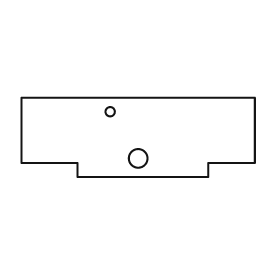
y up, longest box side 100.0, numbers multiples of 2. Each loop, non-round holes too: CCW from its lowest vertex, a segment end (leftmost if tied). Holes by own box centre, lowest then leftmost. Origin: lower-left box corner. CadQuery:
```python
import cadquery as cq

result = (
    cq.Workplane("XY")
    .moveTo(24.0, 0.0)
    .lineTo(80.0, 0.0)
    .lineTo(80.0, 6.0)
    .lineTo(100.0, 6.0)
    .lineTo(100.0, 34.0)
    .lineTo(0.0, 34.0)
    .lineTo(0.0, 6.0)
    .lineTo(24.0, 6.0)
    .close()
    .moveTo(50.0, 8.0)
    .circle(4.0)
    .moveTo(38.0, 28.0)
    .circle(2.0)
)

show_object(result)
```